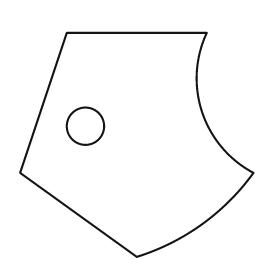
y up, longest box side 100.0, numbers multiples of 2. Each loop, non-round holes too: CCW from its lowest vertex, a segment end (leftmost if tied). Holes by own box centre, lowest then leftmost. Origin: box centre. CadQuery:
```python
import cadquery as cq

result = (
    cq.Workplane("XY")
    .moveTo(0.0, -48.0)
    .threePointArc((28.0, -34.0), (50.0, -12.0))
    .threePointArc((28.0, 14.0), (30.0, 48.0))
    .lineTo(-30.0, 48.0)
    .lineTo(-50.0, -12.0)
    .close()
    .moveTo(-22.0, 8.0)
    .circle(8.0)
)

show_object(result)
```